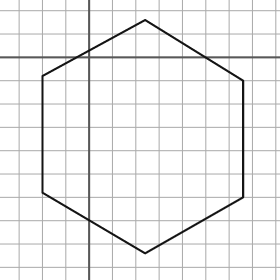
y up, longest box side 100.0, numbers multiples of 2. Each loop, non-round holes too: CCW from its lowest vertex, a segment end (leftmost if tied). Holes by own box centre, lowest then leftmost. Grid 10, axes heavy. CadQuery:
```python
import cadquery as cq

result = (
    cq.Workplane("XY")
    .moveTo(24.0, -84.0)
    .lineTo(66.0, -60.0)
    .lineTo(66.0, -10.0)
    .lineTo(24.0, 16.0)
    .lineTo(-20.0, -8.0)
    .lineTo(-20.0, -58.0)
    .close()
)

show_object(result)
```